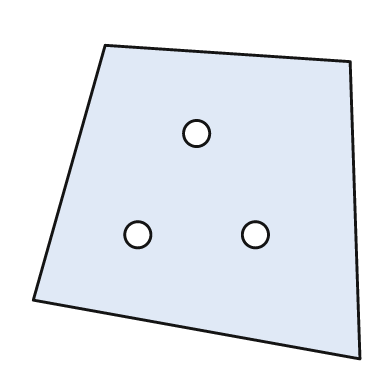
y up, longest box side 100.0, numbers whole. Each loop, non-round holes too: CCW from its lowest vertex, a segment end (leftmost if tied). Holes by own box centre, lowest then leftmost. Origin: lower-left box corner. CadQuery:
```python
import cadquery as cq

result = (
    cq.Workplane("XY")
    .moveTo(100.0, 0.0)
    .lineTo(97.0, 91.0)
    .lineTo(22.0, 96.0)
    .lineTo(0.0, 18.0)
    .close()
    .moveTo(32.0, 38.0)
    .circle(4.0)
    .moveTo(68.0, 38.0)
    .circle(4.0)
    .moveTo(50.0, 69.0)
    .circle(4.0)
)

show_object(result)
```